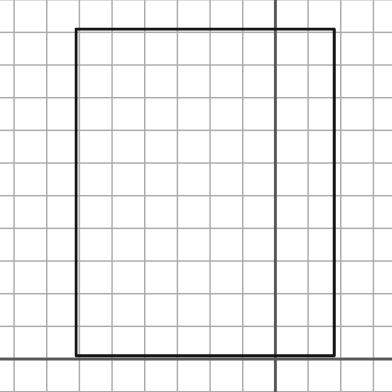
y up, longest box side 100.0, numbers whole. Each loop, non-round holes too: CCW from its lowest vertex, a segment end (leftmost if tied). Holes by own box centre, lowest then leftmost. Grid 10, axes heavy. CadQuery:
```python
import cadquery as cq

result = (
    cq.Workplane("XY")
    .moveTo(-61.0, 1.0)
    .lineTo(18.0, 1.0)
    .lineTo(18.0, 101.0)
    .lineTo(-61.0, 101.0)
    .close()
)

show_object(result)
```